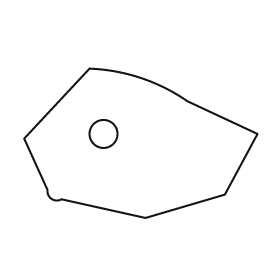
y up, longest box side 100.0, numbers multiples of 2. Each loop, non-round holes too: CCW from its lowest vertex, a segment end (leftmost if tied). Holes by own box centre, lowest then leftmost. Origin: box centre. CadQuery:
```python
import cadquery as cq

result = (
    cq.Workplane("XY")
    .moveTo(2.0, -32.0)
    .lineTo(36.0, -22.0)
    .lineTo(50.0, 4.0)
    .lineTo(20.0, 18.0)
    .threePointArc((0.0, 28.0), (-22.0, 32.0))
    .lineTo(-50.0, 2.0)
    .lineTo(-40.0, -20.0)
    .threePointArc((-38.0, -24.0), (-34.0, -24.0))
    .close()
    .moveTo(-16.0, 4.0)
    .circle(6.0)
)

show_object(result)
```